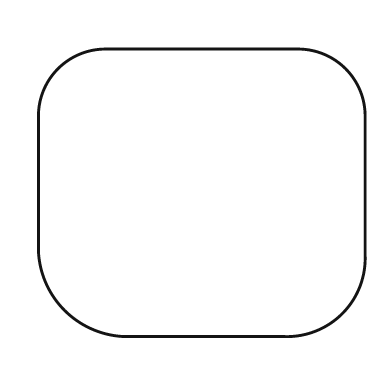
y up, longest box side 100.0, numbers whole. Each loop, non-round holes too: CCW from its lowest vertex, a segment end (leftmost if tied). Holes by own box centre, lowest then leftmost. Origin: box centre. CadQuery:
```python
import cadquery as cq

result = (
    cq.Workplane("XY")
    .moveTo(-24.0, -44.0)
    .lineTo(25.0, -44.0)
    .threePointArc((43.0, -37.0), (50.0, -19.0))
    .lineTo(50.0, 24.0)
    .threePointArc((44.0, 38.0), (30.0, 44.0))
    .lineTo(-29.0, 44.0)
    .threePointArc((-44.0, 38.0), (-50.0, 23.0))
    .lineTo(-50.0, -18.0)
    .threePointArc((-42.0, -36.0), (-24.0, -44.0))
    .close()
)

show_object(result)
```